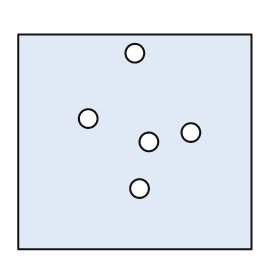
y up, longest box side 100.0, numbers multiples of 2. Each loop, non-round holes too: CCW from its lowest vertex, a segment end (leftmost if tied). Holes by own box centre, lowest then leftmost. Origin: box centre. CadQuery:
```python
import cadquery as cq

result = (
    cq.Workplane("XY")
    .moveTo(-50.0, -46.0)
    .lineTo(50.0, -46.0)
    .lineTo(50.0, 46.0)
    .lineTo(-50.0, 46.0)
    .close()
    .moveTo(2.0, -20.0)
    .circle(4.0)
    .moveTo(6.0, 0.0)
    .circle(4.0)
    .moveTo(24.0, 4.0)
    .circle(4.0)
    .moveTo(-20.0, 10.0)
    .circle(4.0)
    .moveTo(0.0, 38.0)
    .circle(4.0)
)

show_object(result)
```